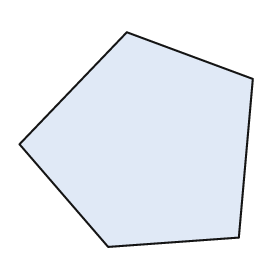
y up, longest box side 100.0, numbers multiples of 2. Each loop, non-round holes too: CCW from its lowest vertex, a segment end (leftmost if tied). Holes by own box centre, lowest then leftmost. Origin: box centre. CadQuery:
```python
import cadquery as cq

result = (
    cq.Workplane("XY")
    .moveTo(-12.0, -46.0)
    .lineTo(44.0, -42.0)
    .lineTo(50.0, 26.0)
    .lineTo(-4.0, 46.0)
    .lineTo(-50.0, -2.0)
    .close()
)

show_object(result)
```